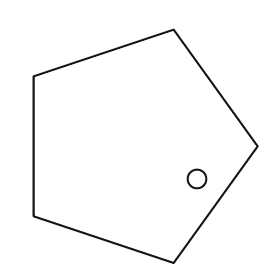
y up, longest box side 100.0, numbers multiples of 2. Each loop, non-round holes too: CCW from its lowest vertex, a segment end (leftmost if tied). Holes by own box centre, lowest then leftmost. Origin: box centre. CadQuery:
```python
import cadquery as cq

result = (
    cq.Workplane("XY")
    .moveTo(12.0, -50.0)
    .lineTo(48.0, 0.0)
    .lineTo(12.0, 50.0)
    .lineTo(-48.0, 30.0)
    .lineTo(-48.0, -30.0)
    .close()
    .moveTo(22.0, -14.0)
    .circle(4.0)
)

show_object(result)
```